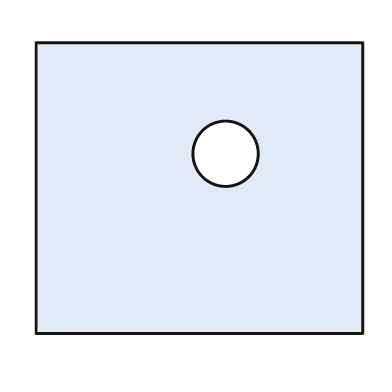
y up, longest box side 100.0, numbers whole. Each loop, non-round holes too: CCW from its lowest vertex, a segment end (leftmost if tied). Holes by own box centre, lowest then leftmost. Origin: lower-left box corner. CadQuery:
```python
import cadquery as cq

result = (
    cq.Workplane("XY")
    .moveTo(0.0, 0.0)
    .lineTo(100.0, 0.0)
    .lineTo(100.0, 89.0)
    .lineTo(0.0, 89.0)
    .close()
    .moveTo(58.0, 55.0)
    .circle(10.0)
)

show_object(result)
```